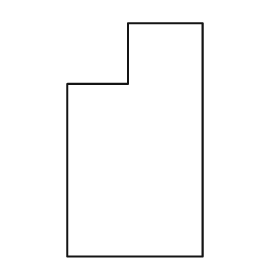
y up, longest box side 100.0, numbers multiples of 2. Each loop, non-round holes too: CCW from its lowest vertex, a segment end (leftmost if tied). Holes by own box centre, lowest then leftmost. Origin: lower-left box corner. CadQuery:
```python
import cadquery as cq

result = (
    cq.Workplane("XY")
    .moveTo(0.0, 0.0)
    .lineTo(58.0, 0.0)
    .lineTo(58.0, 100.0)
    .lineTo(26.0, 100.0)
    .lineTo(26.0, 74.0)
    .lineTo(0.0, 74.0)
    .close()
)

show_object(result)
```